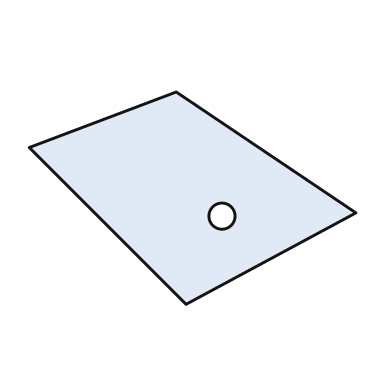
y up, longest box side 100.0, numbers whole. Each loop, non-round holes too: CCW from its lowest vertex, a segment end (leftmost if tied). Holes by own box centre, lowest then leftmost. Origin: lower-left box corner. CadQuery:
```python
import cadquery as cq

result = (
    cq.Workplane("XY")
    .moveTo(48.0, 0.0)
    .lineTo(100.0, 28.0)
    .lineTo(45.0, 65.0)
    .lineTo(0.0, 48.0)
    .close()
    .moveTo(59.0, 27.0)
    .circle(4.0)
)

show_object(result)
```